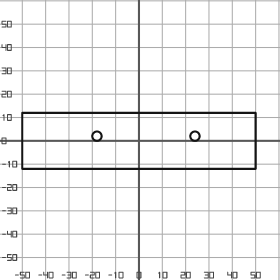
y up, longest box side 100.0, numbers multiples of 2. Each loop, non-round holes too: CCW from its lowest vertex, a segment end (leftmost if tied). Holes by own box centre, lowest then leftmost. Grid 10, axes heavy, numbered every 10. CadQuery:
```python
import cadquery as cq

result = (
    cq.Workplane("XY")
    .moveTo(-50.0, -12.0)
    .lineTo(50.0, -12.0)
    .lineTo(50.0, 12.0)
    .lineTo(-50.0, 12.0)
    .close()
    .moveTo(-18.0, 2.0)
    .circle(2.0)
    .moveTo(24.0, 2.0)
    .circle(2.0)
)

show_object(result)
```